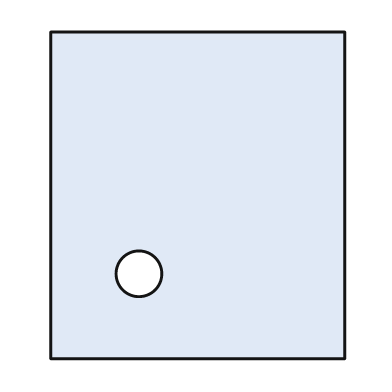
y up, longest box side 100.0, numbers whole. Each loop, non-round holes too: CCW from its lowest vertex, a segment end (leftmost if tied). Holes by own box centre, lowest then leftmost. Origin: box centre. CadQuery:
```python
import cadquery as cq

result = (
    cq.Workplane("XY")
    .moveTo(-45.0, -50.0)
    .lineTo(45.0, -50.0)
    .lineTo(45.0, 50.0)
    .lineTo(-45.0, 50.0)
    .close()
    .moveTo(-18.0, -24.0)
    .circle(7.0)
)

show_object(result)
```